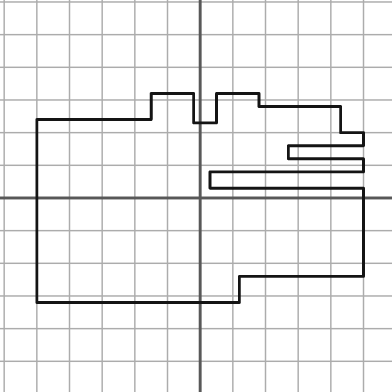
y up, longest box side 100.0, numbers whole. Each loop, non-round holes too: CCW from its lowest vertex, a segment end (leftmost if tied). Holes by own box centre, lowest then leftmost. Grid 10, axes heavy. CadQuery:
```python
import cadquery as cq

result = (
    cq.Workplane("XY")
    .moveTo(-50.0, -32.0)
    .lineTo(12.0, -32.0)
    .lineTo(12.0, -24.0)
    .lineTo(50.0, -24.0)
    .lineTo(50.0, 3.0)
    .lineTo(3.0, 3.0)
    .lineTo(3.0, 8.0)
    .lineTo(50.0, 8.0)
    .lineTo(50.0, 12.0)
    .lineTo(27.0, 12.0)
    .lineTo(27.0, 16.0)
    .lineTo(50.0, 16.0)
    .lineTo(50.0, 20.0)
    .lineTo(43.0, 20.0)
    .lineTo(43.0, 28.0)
    .lineTo(18.0, 28.0)
    .lineTo(18.0, 32.0)
    .lineTo(5.0, 32.0)
    .lineTo(5.0, 23.0)
    .lineTo(-2.0, 23.0)
    .lineTo(-2.0, 32.0)
    .lineTo(-15.0, 32.0)
    .lineTo(-15.0, 24.0)
    .lineTo(-50.0, 24.0)
    .close()
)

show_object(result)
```